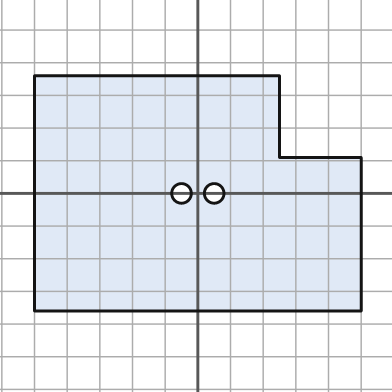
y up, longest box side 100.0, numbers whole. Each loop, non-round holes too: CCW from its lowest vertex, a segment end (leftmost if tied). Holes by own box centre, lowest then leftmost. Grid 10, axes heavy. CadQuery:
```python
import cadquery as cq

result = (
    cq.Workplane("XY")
    .moveTo(-50.0, -36.0)
    .lineTo(50.0, -36.0)
    .lineTo(50.0, 11.0)
    .lineTo(25.0, 11.0)
    .lineTo(25.0, 36.0)
    .lineTo(-50.0, 36.0)
    .close()
    .moveTo(-5.0, 0.0)
    .circle(3.0)
    .moveTo(5.0, 0.0)
    .circle(3.0)
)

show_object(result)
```